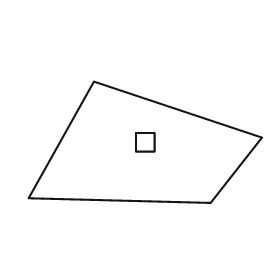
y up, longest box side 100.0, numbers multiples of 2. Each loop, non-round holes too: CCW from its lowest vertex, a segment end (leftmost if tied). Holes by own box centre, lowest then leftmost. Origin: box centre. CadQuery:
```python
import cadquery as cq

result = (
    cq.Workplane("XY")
    .moveTo(28.0, -26.0)
    .lineTo(50.0, 2.0)
    .lineTo(-22.0, 26.0)
    .lineTo(-50.0, -24.0)
    .close()
    .moveTo(-4.0, -4.0)
    .lineTo(4.0, -4.0)
    .lineTo(4.0, 4.0)
    .lineTo(-4.0, 4.0)
    .close()
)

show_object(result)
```